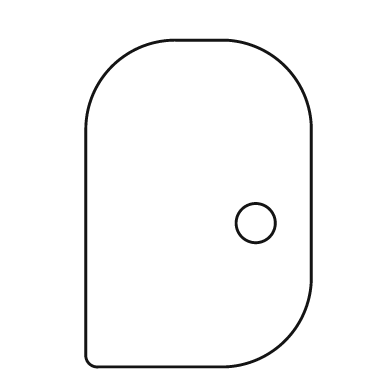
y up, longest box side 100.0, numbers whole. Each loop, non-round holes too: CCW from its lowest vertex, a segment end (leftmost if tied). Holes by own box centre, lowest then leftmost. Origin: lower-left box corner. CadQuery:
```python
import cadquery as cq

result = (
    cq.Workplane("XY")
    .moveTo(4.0, 0.0)
    .lineTo(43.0, 0.0)
    .threePointArc((61.0, 8.0), (69.0, 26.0))
    .lineTo(69.0, 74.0)
    .threePointArc((61.0, 92.0), (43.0, 100.0))
    .lineTo(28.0, 100.0)
    .threePointArc((8.0, 92.0), (0.0, 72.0))
    .lineTo(0.0, 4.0)
    .threePointArc((1.0, 1.0), (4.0, 0.0))
    .close()
    .moveTo(52.0, 44.0)
    .circle(6.0)
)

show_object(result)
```